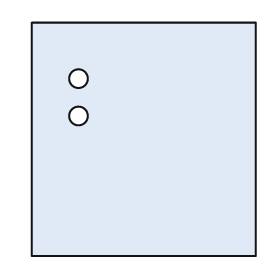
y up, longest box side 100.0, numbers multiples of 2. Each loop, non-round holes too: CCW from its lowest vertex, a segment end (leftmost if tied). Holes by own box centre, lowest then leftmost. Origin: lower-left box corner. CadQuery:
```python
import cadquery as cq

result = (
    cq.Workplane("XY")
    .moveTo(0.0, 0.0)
    .lineTo(96.0, 0.0)
    .lineTo(96.0, 100.0)
    .lineTo(0.0, 100.0)
    .close()
    .moveTo(20.0, 60.0)
    .circle(4.0)
    .moveTo(20.0, 76.0)
    .circle(4.0)
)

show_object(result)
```